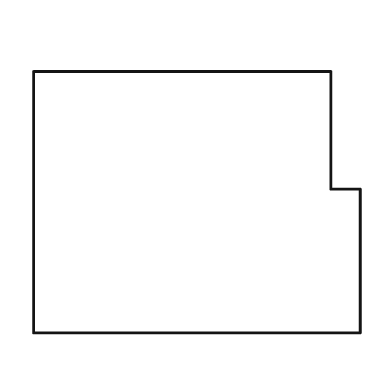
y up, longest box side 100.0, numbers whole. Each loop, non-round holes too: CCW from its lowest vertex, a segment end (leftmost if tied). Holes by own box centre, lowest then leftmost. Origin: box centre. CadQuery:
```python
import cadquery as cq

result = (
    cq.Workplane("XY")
    .moveTo(-50.0, -40.0)
    .lineTo(50.0, -40.0)
    .lineTo(50.0, 4.0)
    .lineTo(41.0, 4.0)
    .lineTo(41.0, 40.0)
    .lineTo(-50.0, 40.0)
    .close()
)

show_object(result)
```